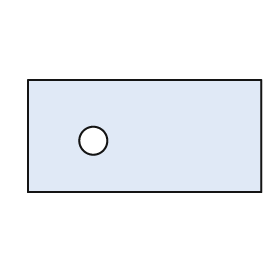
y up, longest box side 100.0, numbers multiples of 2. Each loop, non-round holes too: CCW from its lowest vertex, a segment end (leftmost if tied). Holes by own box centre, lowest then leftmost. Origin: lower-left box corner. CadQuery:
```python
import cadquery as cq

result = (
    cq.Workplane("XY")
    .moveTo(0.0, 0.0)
    .lineTo(100.0, 0.0)
    .lineTo(100.0, 48.0)
    .lineTo(0.0, 48.0)
    .close()
    .moveTo(28.0, 22.0)
    .circle(6.0)
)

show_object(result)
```